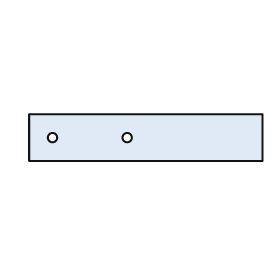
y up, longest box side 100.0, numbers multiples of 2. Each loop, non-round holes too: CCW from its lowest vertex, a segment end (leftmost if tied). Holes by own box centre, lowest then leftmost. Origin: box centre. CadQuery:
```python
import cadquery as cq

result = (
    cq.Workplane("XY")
    .moveTo(-50.0, -10.0)
    .lineTo(50.0, -10.0)
    .lineTo(50.0, 10.0)
    .lineTo(-50.0, 10.0)
    .close()
    .moveTo(-40.0, 0.0)
    .circle(2.0)
    .moveTo(-8.0, 0.0)
    .circle(2.0)
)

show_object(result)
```